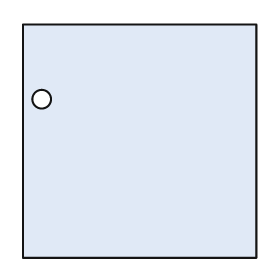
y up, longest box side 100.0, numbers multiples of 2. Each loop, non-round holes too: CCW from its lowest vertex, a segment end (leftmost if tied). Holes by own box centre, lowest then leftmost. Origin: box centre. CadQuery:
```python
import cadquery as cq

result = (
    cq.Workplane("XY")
    .moveTo(-50.0, -50.0)
    .lineTo(50.0, -50.0)
    .lineTo(50.0, 50.0)
    .lineTo(-50.0, 50.0)
    .close()
    .moveTo(-42.0, 18.0)
    .circle(4.0)
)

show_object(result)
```